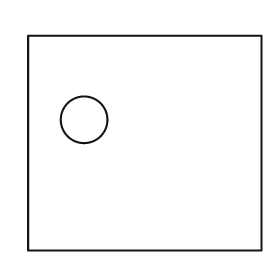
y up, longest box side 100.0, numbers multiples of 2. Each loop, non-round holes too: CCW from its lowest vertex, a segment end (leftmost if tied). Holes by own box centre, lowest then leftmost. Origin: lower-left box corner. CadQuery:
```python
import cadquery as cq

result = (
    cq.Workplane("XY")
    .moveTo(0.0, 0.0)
    .lineTo(100.0, 0.0)
    .lineTo(100.0, 92.0)
    .lineTo(0.0, 92.0)
    .close()
    .moveTo(24.0, 56.0)
    .circle(10.0)
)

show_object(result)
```